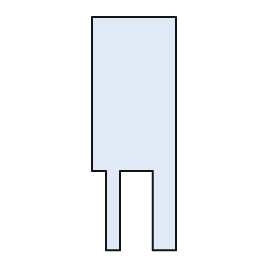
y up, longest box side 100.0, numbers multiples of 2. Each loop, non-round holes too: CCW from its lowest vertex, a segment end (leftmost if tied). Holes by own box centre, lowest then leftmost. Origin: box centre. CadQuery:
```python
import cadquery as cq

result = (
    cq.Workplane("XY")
    .moveTo(-12.0, -50.0)
    .lineTo(-6.0, -50.0)
    .lineTo(-6.0, -16.0)
    .lineTo(8.0, -16.0)
    .lineTo(8.0, -50.0)
    .lineTo(18.0, -50.0)
    .lineTo(18.0, 50.0)
    .lineTo(-18.0, 50.0)
    .lineTo(-18.0, -16.0)
    .lineTo(-12.0, -16.0)
    .close()
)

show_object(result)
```